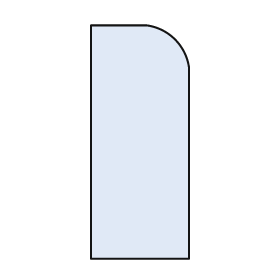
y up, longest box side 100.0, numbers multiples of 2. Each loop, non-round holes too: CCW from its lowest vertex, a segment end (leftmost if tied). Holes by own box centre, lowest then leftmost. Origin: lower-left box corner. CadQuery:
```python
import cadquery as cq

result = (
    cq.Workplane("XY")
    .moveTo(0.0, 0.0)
    .lineTo(42.0, 0.0)
    .lineTo(42.0, 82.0)
    .threePointArc((36.0, 94.0), (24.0, 100.0))
    .lineTo(0.0, 100.0)
    .close()
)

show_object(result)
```